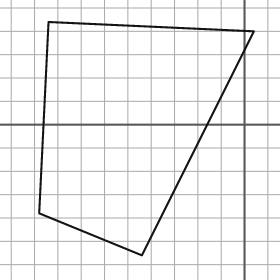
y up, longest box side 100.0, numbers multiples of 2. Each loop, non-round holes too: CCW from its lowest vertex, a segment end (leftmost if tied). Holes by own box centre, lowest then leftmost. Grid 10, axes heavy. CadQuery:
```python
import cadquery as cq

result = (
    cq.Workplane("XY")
    .moveTo(-44.0, -56.0)
    .lineTo(4.0, 40.0)
    .lineTo(-84.0, 44.0)
    .lineTo(-88.0, -38.0)
    .close()
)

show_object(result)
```